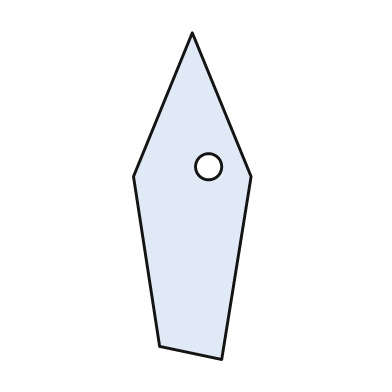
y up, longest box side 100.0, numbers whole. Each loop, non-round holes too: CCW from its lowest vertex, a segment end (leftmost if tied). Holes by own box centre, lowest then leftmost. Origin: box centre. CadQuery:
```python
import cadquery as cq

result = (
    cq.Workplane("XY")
    .moveTo(9.0, -50.0)
    .lineTo(18.0, 6.0)
    .lineTo(0.0, 50.0)
    .lineTo(-18.0, 6.0)
    .lineTo(-10.0, -46.0)
    .close()
    .moveTo(5.0, 9.0)
    .circle(4.0)
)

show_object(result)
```